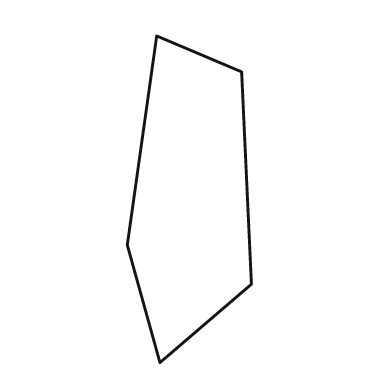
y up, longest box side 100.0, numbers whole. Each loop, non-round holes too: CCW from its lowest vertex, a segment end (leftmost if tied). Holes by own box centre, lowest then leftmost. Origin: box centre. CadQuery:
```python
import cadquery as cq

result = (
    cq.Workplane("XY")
    .moveTo(-9.0, -50.0)
    .lineTo(19.0, -26.0)
    .lineTo(16.0, 39.0)
    .lineTo(-10.0, 50.0)
    .lineTo(-19.0, -14.0)
    .close()
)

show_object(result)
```